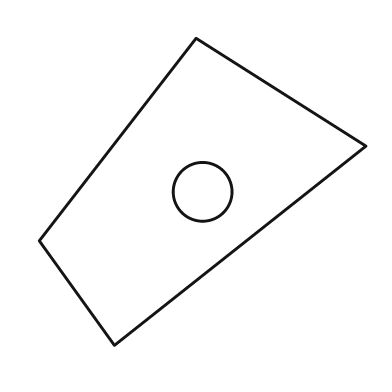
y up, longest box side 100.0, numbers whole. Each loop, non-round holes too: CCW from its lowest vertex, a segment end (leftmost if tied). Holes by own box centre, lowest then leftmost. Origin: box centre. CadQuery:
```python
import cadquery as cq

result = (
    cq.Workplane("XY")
    .moveTo(-27.0, -47.0)
    .lineTo(50.0, 14.0)
    .lineTo(-2.0, 47.0)
    .lineTo(-50.0, -15.0)
    .close()
    .moveTo(0.0, 0.0)
    .circle(9.0)
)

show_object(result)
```